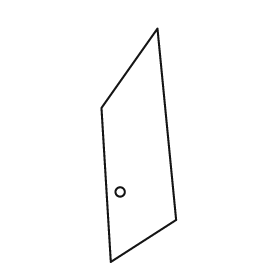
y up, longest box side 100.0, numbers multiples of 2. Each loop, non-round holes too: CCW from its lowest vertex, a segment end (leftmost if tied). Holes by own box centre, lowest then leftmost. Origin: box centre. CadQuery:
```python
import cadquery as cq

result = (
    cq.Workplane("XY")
    .moveTo(-12.0, -50.0)
    .lineTo(16.0, -32.0)
    .lineTo(8.0, 50.0)
    .lineTo(-16.0, 16.0)
    .close()
    .moveTo(-8.0, -20.0)
    .circle(2.0)
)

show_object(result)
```